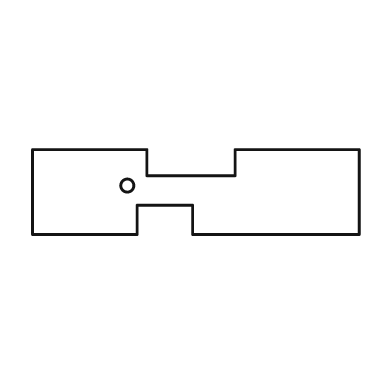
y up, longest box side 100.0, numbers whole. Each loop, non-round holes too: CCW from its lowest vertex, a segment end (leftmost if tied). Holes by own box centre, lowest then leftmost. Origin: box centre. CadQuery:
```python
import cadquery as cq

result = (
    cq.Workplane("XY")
    .moveTo(-50.0, -13.0)
    .lineTo(-18.0, -13.0)
    .lineTo(-18.0, -4.0)
    .lineTo(-1.0, -4.0)
    .lineTo(-1.0, -13.0)
    .lineTo(50.0, -13.0)
    .lineTo(50.0, 13.0)
    .lineTo(12.0, 13.0)
    .lineTo(12.0, 5.0)
    .lineTo(-15.0, 5.0)
    .lineTo(-15.0, 13.0)
    .lineTo(-50.0, 13.0)
    .close()
    .moveTo(-21.0, 2.0)
    .circle(2.0)
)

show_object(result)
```